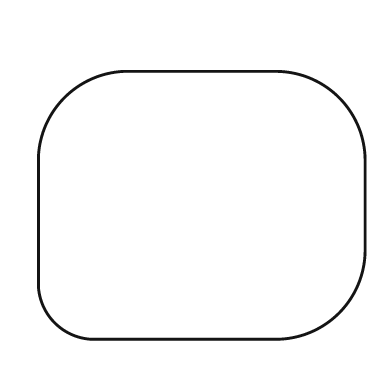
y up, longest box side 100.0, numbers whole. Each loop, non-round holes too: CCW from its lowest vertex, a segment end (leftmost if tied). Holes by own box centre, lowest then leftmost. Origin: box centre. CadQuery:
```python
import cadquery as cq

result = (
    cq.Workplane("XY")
    .moveTo(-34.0, -41.0)
    .lineTo(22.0, -41.0)
    .threePointArc((42.0, -33.0), (50.0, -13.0))
    .lineTo(50.0, 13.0)
    .threePointArc((42.0, 33.0), (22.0, 41.0))
    .lineTo(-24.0, 41.0)
    .threePointArc((-42.0, 33.0), (-50.0, 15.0))
    .lineTo(-50.0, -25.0)
    .threePointArc((-45.0, -36.0), (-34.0, -41.0))
    .close()
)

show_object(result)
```